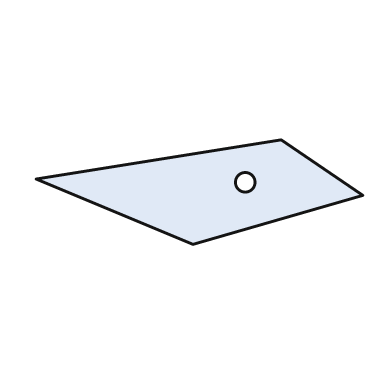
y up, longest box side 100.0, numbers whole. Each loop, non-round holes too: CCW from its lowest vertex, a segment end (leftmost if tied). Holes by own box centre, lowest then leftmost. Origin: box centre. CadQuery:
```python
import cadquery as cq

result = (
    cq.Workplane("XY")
    .moveTo(-2.0, -16.0)
    .lineTo(50.0, -1.0)
    .lineTo(25.0, 16.0)
    .lineTo(-50.0, 4.0)
    .close()
    .moveTo(14.0, 3.0)
    .circle(3.0)
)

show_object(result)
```